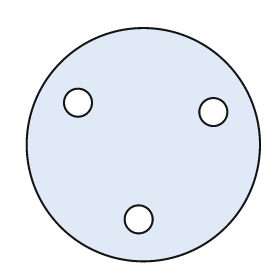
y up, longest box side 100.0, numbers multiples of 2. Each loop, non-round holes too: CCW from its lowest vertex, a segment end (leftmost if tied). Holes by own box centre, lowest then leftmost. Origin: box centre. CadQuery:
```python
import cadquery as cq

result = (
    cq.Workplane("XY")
    .moveTo(0.0, 0.0)
    .circle(50.0)
    .moveTo(-2.0, -32.0)
    .circle(6.0)
    .moveTo(30.0, 14.0)
    .circle(6.0)
    .moveTo(-28.0, 18.0)
    .circle(6.0)
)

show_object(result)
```